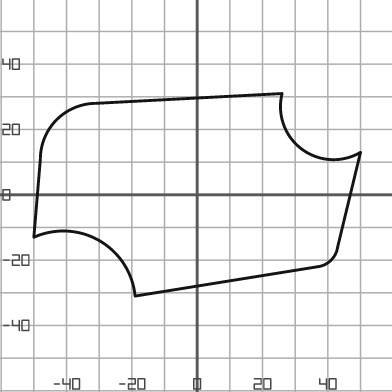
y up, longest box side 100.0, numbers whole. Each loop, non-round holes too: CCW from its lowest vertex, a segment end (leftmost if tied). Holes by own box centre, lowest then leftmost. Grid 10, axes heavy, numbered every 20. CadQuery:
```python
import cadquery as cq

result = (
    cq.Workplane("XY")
    .moveTo(-19.0, -31.0)
    .lineTo(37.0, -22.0)
    .threePointArc((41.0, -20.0), (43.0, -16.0))
    .lineTo(50.0, 13.0)
    .threePointArc((32.0, 14.0), (26.0, 31.0))
    .lineTo(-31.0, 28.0)
    .threePointArc((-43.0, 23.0), (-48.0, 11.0))
    .lineTo(-50.0, -13.0)
    .threePointArc((-30.0, -14.0), (-19.0, -31.0))
    .close()
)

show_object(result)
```